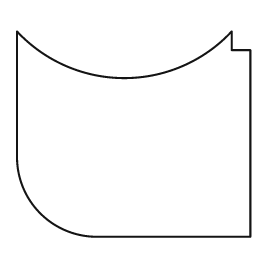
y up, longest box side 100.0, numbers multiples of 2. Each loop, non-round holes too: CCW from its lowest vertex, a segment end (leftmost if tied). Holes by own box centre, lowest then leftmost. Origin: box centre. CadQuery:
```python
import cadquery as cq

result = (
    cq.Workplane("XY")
    .moveTo(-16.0, -44.0)
    .lineTo(50.0, -44.0)
    .lineTo(50.0, 36.0)
    .lineTo(42.0, 36.0)
    .lineTo(42.0, 44.0)
    .threePointArc((-4.0, 24.0), (-50.0, 44.0))
    .lineTo(-50.0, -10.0)
    .threePointArc((-40.0, -34.0), (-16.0, -44.0))
    .close()
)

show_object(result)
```